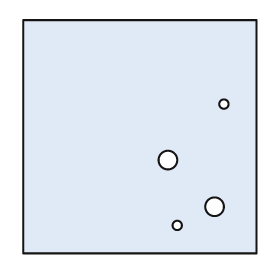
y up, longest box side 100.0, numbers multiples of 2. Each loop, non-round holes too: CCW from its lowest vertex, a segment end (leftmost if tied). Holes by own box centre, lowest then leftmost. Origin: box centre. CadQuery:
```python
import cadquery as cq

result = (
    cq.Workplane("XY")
    .moveTo(-50.0, -50.0)
    .lineTo(50.0, -50.0)
    .lineTo(50.0, 50.0)
    .lineTo(-50.0, 50.0)
    .close()
    .moveTo(16.0, -38.0)
    .circle(2.0)
    .moveTo(32.0, -30.0)
    .circle(4.0)
    .moveTo(12.0, -10.0)
    .circle(4.0)
    .moveTo(36.0, 14.0)
    .circle(2.0)
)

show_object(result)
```